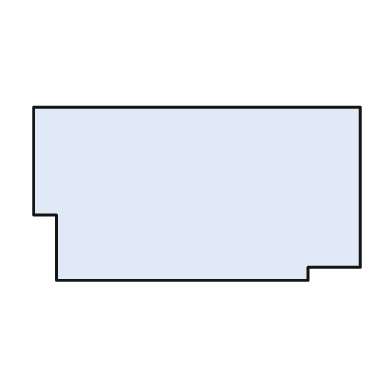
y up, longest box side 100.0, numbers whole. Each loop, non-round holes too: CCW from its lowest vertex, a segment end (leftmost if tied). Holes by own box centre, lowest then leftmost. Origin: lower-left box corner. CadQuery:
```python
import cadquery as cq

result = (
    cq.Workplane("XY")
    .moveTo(7.0, 0.0)
    .lineTo(84.0, 0.0)
    .lineTo(84.0, 4.0)
    .lineTo(100.0, 4.0)
    .lineTo(100.0, 53.0)
    .lineTo(0.0, 53.0)
    .lineTo(0.0, 20.0)
    .lineTo(7.0, 20.0)
    .close()
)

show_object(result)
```